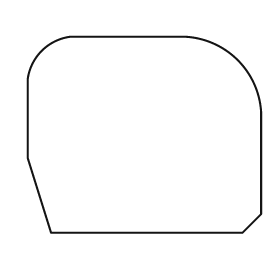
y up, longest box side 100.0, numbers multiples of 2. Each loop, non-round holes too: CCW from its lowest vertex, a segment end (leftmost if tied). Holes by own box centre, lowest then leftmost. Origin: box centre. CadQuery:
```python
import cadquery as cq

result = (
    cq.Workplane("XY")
    .moveTo(-40.0, -42.0)
    .lineTo(42.0, -42.0)
    .lineTo(50.0, -34.0)
    .lineTo(50.0, 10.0)
    .threePointArc((40.0, 32.0), (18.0, 42.0))
    .lineTo(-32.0, 42.0)
    .threePointArc((-44.0, 36.0), (-50.0, 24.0))
    .lineTo(-50.0, -10.0)
    .close()
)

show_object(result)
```